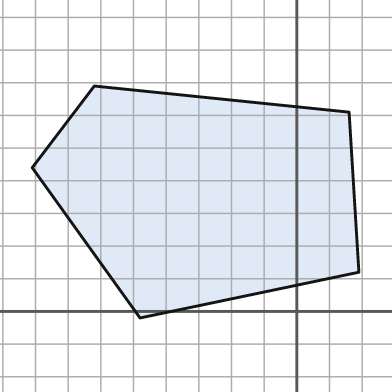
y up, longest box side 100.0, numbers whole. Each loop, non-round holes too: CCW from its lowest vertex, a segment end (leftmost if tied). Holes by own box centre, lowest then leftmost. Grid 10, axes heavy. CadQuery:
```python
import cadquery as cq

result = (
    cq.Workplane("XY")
    .moveTo(-48.0, -2.0)
    .lineTo(19.0, 12.0)
    .lineTo(16.0, 61.0)
    .lineTo(-62.0, 69.0)
    .lineTo(-81.0, 44.0)
    .close()
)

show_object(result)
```